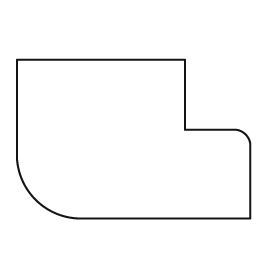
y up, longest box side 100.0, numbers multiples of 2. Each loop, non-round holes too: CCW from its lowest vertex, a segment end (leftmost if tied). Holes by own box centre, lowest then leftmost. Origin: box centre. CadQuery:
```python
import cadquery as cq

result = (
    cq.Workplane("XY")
    .moveTo(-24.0, -34.0)
    .lineTo(50.0, -34.0)
    .lineTo(50.0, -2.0)
    .threePointArc((48.0, 2.0), (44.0, 4.0))
    .lineTo(22.0, 4.0)
    .lineTo(22.0, 34.0)
    .lineTo(-50.0, 34.0)
    .lineTo(-50.0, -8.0)
    .threePointArc((-42.0, -26.0), (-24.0, -34.0))
    .close()
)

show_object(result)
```